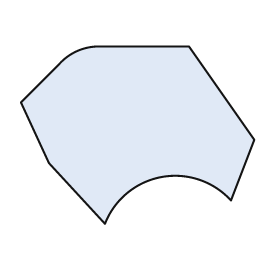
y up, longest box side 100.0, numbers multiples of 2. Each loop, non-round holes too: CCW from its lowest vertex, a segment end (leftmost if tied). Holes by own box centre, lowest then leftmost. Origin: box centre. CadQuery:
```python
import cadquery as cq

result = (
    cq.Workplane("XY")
    .moveTo(-14.0, -38.0)
    .threePointArc((10.0, -18.0), (40.0, -28.0))
    .lineTo(50.0, -2.0)
    .lineTo(22.0, 38.0)
    .lineTo(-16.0, 38.0)
    .threePointArc((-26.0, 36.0), (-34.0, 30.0))
    .lineTo(-50.0, 14.0)
    .lineTo(-38.0, -12.0)
    .close()
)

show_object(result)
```